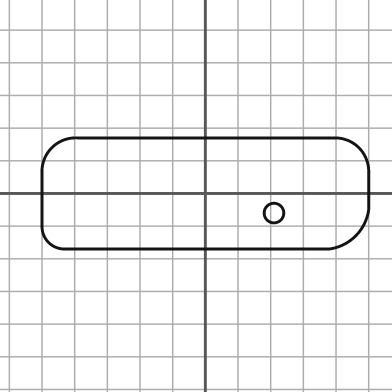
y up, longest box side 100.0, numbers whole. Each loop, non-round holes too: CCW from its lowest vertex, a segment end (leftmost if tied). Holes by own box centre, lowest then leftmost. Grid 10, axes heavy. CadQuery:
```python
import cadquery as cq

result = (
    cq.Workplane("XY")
    .moveTo(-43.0, -17.0)
    .lineTo(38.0, -17.0)
    .threePointArc((46.0, -13.0), (50.0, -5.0))
    .lineTo(50.0, 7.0)
    .threePointArc((47.0, 14.0), (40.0, 17.0))
    .lineTo(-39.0, 17.0)
    .threePointArc((-47.0, 14.0), (-50.0, 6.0))
    .lineTo(-50.0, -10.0)
    .threePointArc((-48.0, -15.0), (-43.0, -17.0))
    .close()
    .moveTo(21.0, -6.0)
    .circle(3.0)
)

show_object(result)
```